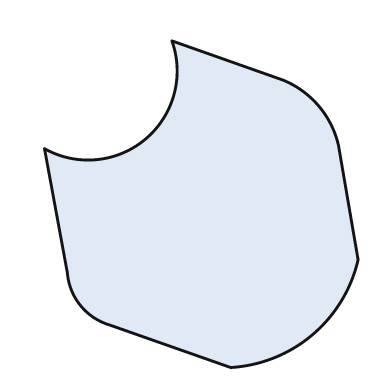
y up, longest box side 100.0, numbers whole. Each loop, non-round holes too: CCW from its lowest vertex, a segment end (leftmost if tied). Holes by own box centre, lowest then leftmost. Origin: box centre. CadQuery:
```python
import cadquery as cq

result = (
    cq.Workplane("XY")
    .moveTo(9.0, -50.0)
    .threePointArc((34.0, -40.0), (48.0, -17.0))
    .lineTo(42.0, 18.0)
    .threePointArc((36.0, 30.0), (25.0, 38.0))
    .lineTo(-9.0, 50.0)
    .threePointArc((-17.0, 20.0), (-48.0, 17.0))
    .lineTo(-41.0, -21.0)
    .threePointArc((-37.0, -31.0), (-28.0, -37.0))
    .close()
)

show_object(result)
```